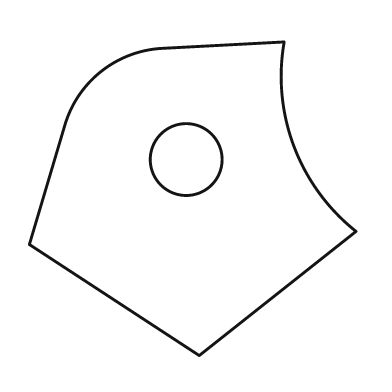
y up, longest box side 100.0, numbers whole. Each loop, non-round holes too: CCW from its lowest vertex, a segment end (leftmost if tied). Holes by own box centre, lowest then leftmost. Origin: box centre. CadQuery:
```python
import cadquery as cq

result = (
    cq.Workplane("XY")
    .moveTo(2.0, -48.0)
    .lineTo(50.0, -10.0)
    .threePointArc((31.0, 16.0), (28.0, 48.0))
    .lineTo(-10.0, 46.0)
    .threePointArc((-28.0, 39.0), (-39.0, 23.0))
    .lineTo(-50.0, -14.0)
    .close()
    .moveTo(-2.0, 12.0)
    .circle(11.0)
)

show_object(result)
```